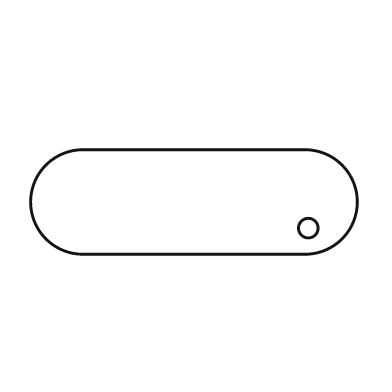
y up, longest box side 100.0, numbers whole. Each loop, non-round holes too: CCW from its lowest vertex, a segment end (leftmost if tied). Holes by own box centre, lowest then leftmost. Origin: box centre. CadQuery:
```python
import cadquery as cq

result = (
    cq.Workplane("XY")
    .moveTo(-34.0, -16.0)
    .lineTo(34.0, -16.0)
    .threePointArc((50.0, 0.0), (34.0, 16.0))
    .lineTo(-34.0, 16.0)
    .threePointArc((-50.0, 0.0), (-34.0, -16.0))
    .close()
    .moveTo(35.0, -8.0)
    .circle(3.0)
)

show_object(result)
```